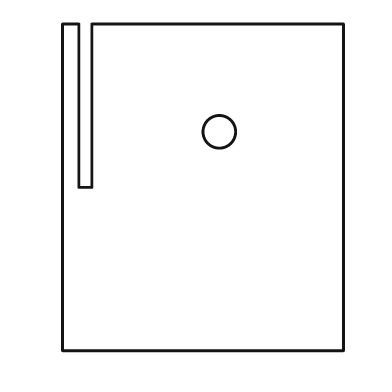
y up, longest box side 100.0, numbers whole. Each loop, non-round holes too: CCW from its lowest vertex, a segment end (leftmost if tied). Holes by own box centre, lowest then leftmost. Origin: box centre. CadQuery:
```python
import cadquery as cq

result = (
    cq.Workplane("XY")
    .moveTo(-43.0, -50.0)
    .lineTo(43.0, -50.0)
    .lineTo(43.0, 50.0)
    .lineTo(-34.0, 50.0)
    .lineTo(-34.0, 0.0)
    .lineTo(-38.0, 0.0)
    .lineTo(-38.0, 50.0)
    .lineTo(-43.0, 50.0)
    .close()
    .moveTo(5.0, 17.0)
    .circle(5.0)
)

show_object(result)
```